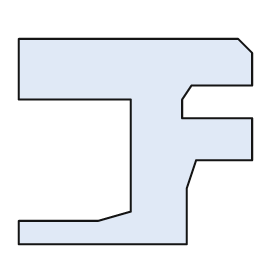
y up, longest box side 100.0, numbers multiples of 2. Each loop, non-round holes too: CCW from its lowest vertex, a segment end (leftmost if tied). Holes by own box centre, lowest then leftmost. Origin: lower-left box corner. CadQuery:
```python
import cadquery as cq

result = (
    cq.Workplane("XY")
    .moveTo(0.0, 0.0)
    .lineTo(72.0, 0.0)
    .lineTo(72.0, 24.0)
    .lineTo(76.0, 36.0)
    .lineTo(100.0, 36.0)
    .lineTo(100.0, 54.0)
    .lineTo(70.0, 54.0)
    .lineTo(70.0, 62.0)
    .lineTo(74.0, 68.0)
    .lineTo(100.0, 68.0)
    .lineTo(100.0, 82.0)
    .lineTo(94.0, 88.0)
    .lineTo(0.0, 88.0)
    .lineTo(0.0, 62.0)
    .lineTo(48.0, 62.0)
    .lineTo(48.0, 14.0)
    .lineTo(34.0, 10.0)
    .lineTo(0.0, 10.0)
    .close()
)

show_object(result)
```